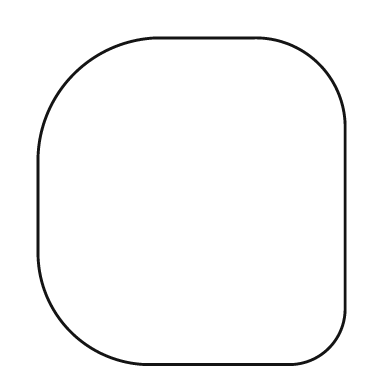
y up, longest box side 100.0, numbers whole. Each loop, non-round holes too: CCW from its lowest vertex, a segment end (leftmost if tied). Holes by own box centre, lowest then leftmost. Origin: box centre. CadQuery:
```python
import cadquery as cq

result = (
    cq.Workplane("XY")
    .moveTo(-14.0, -50.0)
    .lineTo(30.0, -50.0)
    .threePointArc((42.0, -45.0), (47.0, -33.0))
    .lineTo(47.0, 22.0)
    .threePointArc((39.0, 42.0), (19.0, 50.0))
    .lineTo(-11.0, 50.0)
    .threePointArc((-36.0, 39.0), (-47.0, 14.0))
    .lineTo(-47.0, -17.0)
    .threePointArc((-37.0, -40.0), (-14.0, -50.0))
    .close()
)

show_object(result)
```